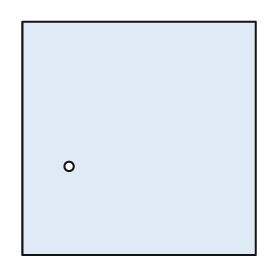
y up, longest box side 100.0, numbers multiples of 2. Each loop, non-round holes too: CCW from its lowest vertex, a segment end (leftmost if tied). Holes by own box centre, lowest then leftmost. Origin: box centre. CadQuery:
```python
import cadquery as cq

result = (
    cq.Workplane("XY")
    .moveTo(-50.0, -50.0)
    .lineTo(50.0, -50.0)
    .lineTo(50.0, 50.0)
    .lineTo(-50.0, 50.0)
    .close()
    .moveTo(-30.0, -12.0)
    .circle(2.0)
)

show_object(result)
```